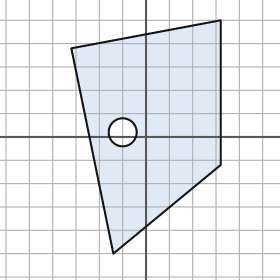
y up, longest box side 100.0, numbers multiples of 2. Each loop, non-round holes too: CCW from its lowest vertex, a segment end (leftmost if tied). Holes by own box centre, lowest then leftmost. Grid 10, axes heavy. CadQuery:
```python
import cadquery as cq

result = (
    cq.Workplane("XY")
    .moveTo(-14.0, -50.0)
    .lineTo(32.0, -12.0)
    .lineTo(32.0, 50.0)
    .lineTo(-32.0, 38.0)
    .close()
    .moveTo(-10.0, 2.0)
    .circle(6.0)
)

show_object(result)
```